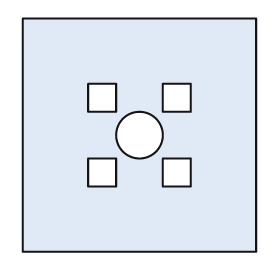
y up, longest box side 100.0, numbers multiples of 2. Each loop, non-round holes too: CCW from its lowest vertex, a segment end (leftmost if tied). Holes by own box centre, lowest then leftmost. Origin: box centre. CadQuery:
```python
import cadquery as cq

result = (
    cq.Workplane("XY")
    .moveTo(-50.0, -50.0)
    .lineTo(50.0, -50.0)
    .lineTo(50.0, 50.0)
    .lineTo(-50.0, 50.0)
    .close()
    .moveTo(-22.0, -22.0)
    .lineTo(-10.0, -22.0)
    .lineTo(-10.0, -10.0)
    .lineTo(-22.0, -10.0)
    .close()
    .moveTo(10.0, -22.0)
    .lineTo(22.0, -22.0)
    .lineTo(22.0, -10.0)
    .lineTo(10.0, -10.0)
    .close()
    .moveTo(0.0, 0.0)
    .circle(10.0)
    .moveTo(-22.0, 10.0)
    .lineTo(-10.0, 10.0)
    .lineTo(-10.0, 22.0)
    .lineTo(-22.0, 22.0)
    .close()
    .moveTo(10.0, 10.0)
    .lineTo(22.0, 10.0)
    .lineTo(22.0, 22.0)
    .lineTo(10.0, 22.0)
    .close()
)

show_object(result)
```